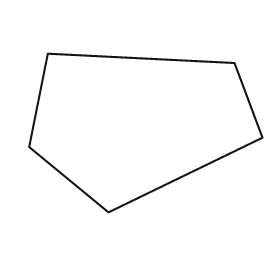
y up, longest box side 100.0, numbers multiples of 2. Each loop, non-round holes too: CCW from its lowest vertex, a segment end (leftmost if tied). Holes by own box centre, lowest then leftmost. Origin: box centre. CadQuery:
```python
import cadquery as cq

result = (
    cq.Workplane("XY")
    .moveTo(-16.0, -34.0)
    .lineTo(50.0, -2.0)
    .lineTo(38.0, 30.0)
    .lineTo(-42.0, 34.0)
    .lineTo(-50.0, -6.0)
    .close()
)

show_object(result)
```